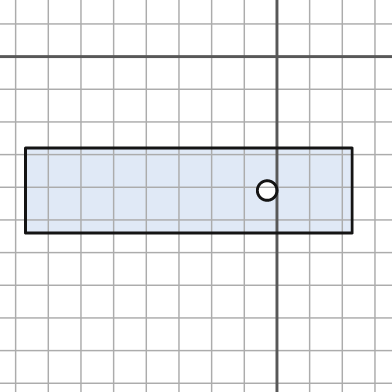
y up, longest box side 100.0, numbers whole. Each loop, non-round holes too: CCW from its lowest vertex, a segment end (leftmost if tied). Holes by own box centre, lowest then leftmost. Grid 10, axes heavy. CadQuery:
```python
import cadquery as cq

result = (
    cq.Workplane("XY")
    .moveTo(-77.0, -54.0)
    .lineTo(23.0, -54.0)
    .lineTo(23.0, -28.0)
    .lineTo(-77.0, -28.0)
    .close()
    .moveTo(-3.0, -41.0)
    .circle(3.0)
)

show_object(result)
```